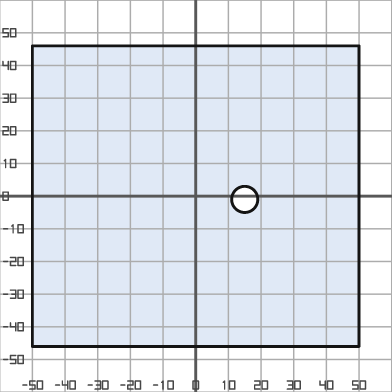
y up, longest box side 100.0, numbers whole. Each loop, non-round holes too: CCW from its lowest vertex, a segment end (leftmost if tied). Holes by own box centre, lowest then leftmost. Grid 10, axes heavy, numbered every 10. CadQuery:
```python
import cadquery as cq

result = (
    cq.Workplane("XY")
    .moveTo(-50.0, -46.0)
    .lineTo(50.0, -46.0)
    .lineTo(50.0, 46.0)
    .lineTo(-50.0, 46.0)
    .close()
    .moveTo(15.0, -1.0)
    .circle(4.0)
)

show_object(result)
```